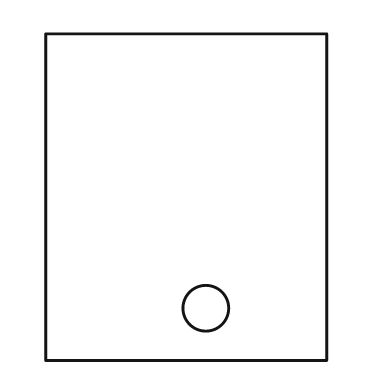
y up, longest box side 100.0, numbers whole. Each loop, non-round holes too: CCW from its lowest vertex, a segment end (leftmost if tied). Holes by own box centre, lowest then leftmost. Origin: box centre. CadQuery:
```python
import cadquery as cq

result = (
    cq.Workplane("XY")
    .moveTo(-43.0, -50.0)
    .lineTo(43.0, -50.0)
    .lineTo(43.0, 50.0)
    .lineTo(-43.0, 50.0)
    .close()
    .moveTo(6.0, -34.0)
    .circle(7.0)
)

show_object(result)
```